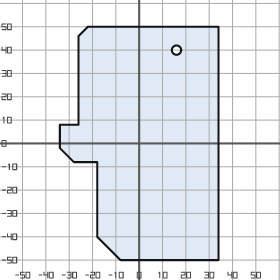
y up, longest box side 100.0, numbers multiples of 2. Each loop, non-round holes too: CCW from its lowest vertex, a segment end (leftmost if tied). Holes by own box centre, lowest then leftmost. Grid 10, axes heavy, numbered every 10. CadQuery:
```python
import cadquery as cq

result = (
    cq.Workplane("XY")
    .moveTo(-8.0, -50.0)
    .lineTo(34.0, -50.0)
    .lineTo(34.0, 50.0)
    .lineTo(-22.0, 50.0)
    .lineTo(-26.0, 46.0)
    .lineTo(-26.0, 8.0)
    .lineTo(-34.0, 8.0)
    .lineTo(-34.0, -2.0)
    .lineTo(-28.0, -8.0)
    .lineTo(-18.0, -8.0)
    .lineTo(-18.0, -40.0)
    .close()
    .moveTo(16.0, 40.0)
    .circle(2.0)
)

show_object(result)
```